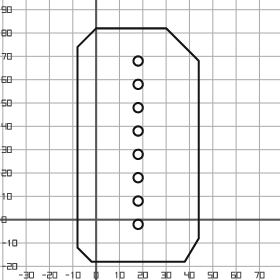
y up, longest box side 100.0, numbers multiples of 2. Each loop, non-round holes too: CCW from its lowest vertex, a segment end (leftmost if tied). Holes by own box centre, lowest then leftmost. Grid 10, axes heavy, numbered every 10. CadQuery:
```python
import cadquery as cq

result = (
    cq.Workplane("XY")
    .moveTo(-2.0, -18.0)
    .lineTo(38.0, -18.0)
    .lineTo(44.0, -8.0)
    .lineTo(44.0, 68.0)
    .lineTo(30.0, 82.0)
    .lineTo(0.0, 82.0)
    .lineTo(-8.0, 74.0)
    .lineTo(-8.0, -12.0)
    .close()
    .moveTo(18.0, -2.0)
    .circle(2.0)
    .moveTo(18.0, 8.0)
    .circle(2.0)
    .moveTo(18.0, 18.0)
    .circle(2.0)
    .moveTo(18.0, 28.0)
    .circle(2.0)
    .moveTo(18.0, 38.0)
    .circle(2.0)
    .moveTo(18.0, 48.0)
    .circle(2.0)
    .moveTo(18.0, 58.0)
    .circle(2.0)
    .moveTo(18.0, 68.0)
    .circle(2.0)
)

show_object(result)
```